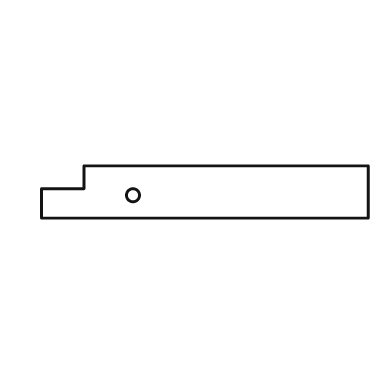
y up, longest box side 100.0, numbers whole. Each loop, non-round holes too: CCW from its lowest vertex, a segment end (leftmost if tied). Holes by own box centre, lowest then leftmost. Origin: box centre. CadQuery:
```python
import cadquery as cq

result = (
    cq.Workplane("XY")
    .moveTo(-50.0, -8.0)
    .lineTo(50.0, -8.0)
    .lineTo(50.0, 8.0)
    .lineTo(-37.0, 8.0)
    .lineTo(-37.0, 1.0)
    .lineTo(-50.0, 1.0)
    .close()
    .moveTo(-22.0, -1.0)
    .circle(2.0)
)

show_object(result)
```